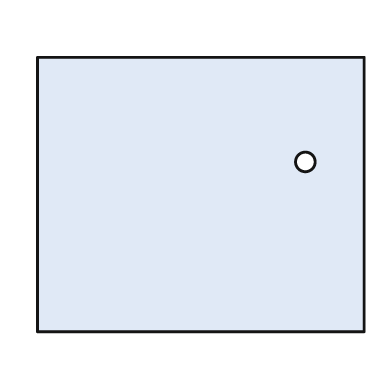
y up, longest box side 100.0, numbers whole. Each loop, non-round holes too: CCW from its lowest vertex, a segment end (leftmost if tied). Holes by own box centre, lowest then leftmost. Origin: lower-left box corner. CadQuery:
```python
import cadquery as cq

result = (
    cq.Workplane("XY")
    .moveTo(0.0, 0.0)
    .lineTo(100.0, 0.0)
    .lineTo(100.0, 84.0)
    .lineTo(0.0, 84.0)
    .close()
    .moveTo(82.0, 52.0)
    .circle(3.0)
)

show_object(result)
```